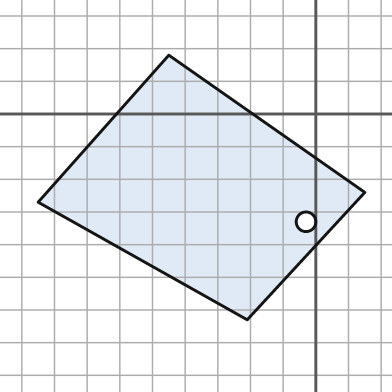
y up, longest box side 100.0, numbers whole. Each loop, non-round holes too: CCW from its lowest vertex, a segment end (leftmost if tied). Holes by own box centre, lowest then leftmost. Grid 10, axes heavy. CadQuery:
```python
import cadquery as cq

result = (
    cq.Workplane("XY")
    .moveTo(-21.0, -63.0)
    .lineTo(15.0, -24.0)
    .lineTo(-45.0, 18.0)
    .lineTo(-85.0, -27.0)
    .close()
    .moveTo(-3.0, -33.0)
    .circle(3.0)
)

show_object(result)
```